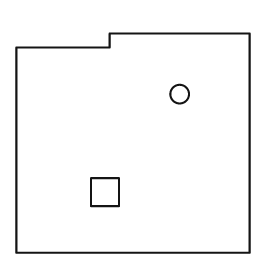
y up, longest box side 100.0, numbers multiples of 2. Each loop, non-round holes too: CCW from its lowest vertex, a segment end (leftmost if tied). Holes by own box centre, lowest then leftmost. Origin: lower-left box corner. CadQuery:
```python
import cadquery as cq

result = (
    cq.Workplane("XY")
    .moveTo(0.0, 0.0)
    .lineTo(100.0, 0.0)
    .lineTo(100.0, 94.0)
    .lineTo(40.0, 94.0)
    .lineTo(40.0, 88.0)
    .lineTo(0.0, 88.0)
    .close()
    .moveTo(32.0, 20.0)
    .lineTo(44.0, 20.0)
    .lineTo(44.0, 32.0)
    .lineTo(32.0, 32.0)
    .close()
    .moveTo(70.0, 68.0)
    .circle(4.0)
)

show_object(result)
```